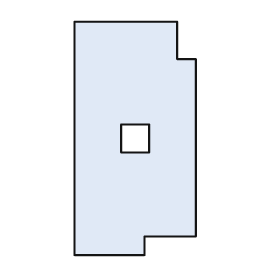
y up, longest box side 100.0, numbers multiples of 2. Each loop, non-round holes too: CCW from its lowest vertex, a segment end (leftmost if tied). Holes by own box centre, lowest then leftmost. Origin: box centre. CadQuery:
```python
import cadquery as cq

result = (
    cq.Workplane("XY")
    .moveTo(-26.0, -50.0)
    .lineTo(4.0, -50.0)
    .lineTo(4.0, -42.0)
    .lineTo(26.0, -42.0)
    .lineTo(26.0, 34.0)
    .lineTo(18.0, 34.0)
    .lineTo(18.0, 50.0)
    .lineTo(-26.0, 50.0)
    .close()
    .moveTo(-6.0, -6.0)
    .lineTo(6.0, -6.0)
    .lineTo(6.0, 6.0)
    .lineTo(-6.0, 6.0)
    .close()
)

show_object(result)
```